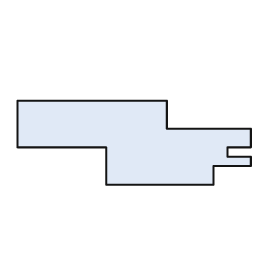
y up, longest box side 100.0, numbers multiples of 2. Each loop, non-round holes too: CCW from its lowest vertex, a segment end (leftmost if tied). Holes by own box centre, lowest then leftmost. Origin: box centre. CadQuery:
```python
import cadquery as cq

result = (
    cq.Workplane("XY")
    .moveTo(-12.0, -18.0)
    .lineTo(34.0, -18.0)
    .lineTo(34.0, -10.0)
    .lineTo(50.0, -10.0)
    .lineTo(50.0, -6.0)
    .lineTo(40.0, -6.0)
    .lineTo(40.0, -2.0)
    .lineTo(50.0, -2.0)
    .lineTo(50.0, 6.0)
    .lineTo(14.0, 6.0)
    .lineTo(14.0, 18.0)
    .lineTo(-50.0, 18.0)
    .lineTo(-50.0, -2.0)
    .lineTo(-12.0, -2.0)
    .close()
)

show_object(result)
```